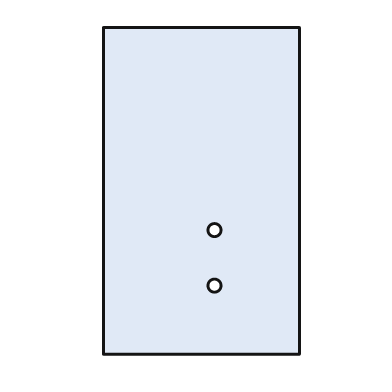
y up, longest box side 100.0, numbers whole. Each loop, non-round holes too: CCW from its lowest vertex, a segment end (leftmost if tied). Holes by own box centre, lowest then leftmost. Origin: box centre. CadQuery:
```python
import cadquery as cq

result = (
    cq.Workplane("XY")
    .moveTo(-30.0, -50.0)
    .lineTo(30.0, -50.0)
    .lineTo(30.0, 50.0)
    .lineTo(-30.0, 50.0)
    .close()
    .moveTo(4.0, -29.0)
    .circle(2.0)
    .moveTo(4.0, -12.0)
    .circle(2.0)
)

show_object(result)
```